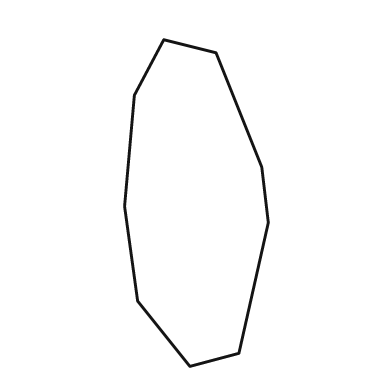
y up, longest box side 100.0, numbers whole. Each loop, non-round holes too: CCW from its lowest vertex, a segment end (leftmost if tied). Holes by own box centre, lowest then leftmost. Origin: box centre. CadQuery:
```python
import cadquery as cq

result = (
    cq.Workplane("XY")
    .moveTo(-2.0, -50.0)
    .lineTo(13.0, -46.0)
    .lineTo(22.0, -6.0)
    .lineTo(20.0, 11.0)
    .lineTo(6.0, 46.0)
    .lineTo(-10.0, 50.0)
    .lineTo(-19.0, 33.0)
    .lineTo(-22.0, -1.0)
    .lineTo(-18.0, -30.0)
    .close()
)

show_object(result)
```